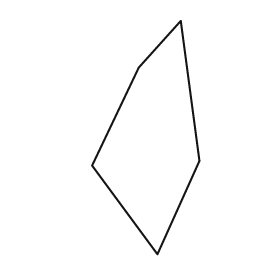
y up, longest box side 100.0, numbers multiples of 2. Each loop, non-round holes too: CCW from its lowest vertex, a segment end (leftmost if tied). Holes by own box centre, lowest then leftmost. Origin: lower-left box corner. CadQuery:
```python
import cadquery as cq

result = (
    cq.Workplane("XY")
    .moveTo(28.0, 0.0)
    .lineTo(46.0, 40.0)
    .lineTo(38.0, 100.0)
    .lineTo(20.0, 80.0)
    .lineTo(0.0, 38.0)
    .close()
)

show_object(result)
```